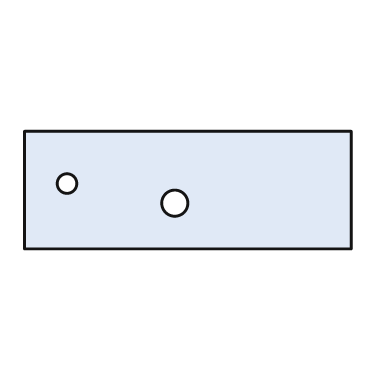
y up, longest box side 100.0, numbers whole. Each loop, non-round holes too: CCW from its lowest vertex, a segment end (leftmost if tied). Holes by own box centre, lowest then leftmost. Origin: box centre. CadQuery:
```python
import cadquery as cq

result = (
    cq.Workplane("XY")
    .moveTo(-50.0, -18.0)
    .lineTo(50.0, -18.0)
    .lineTo(50.0, 18.0)
    .lineTo(-50.0, 18.0)
    .close()
    .moveTo(-4.0, -4.0)
    .circle(4.0)
    .moveTo(-37.0, 2.0)
    .circle(3.0)
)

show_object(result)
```